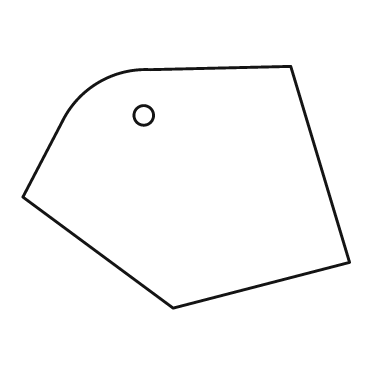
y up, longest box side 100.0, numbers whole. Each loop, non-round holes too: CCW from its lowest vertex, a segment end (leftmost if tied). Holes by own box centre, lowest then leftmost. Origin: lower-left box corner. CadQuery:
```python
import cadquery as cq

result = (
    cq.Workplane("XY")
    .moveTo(46.0, 0.0)
    .lineTo(100.0, 14.0)
    .lineTo(82.0, 74.0)
    .lineTo(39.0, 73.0)
    .threePointArc((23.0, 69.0), (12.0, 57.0))
    .lineTo(0.0, 34.0)
    .close()
    .moveTo(37.0, 59.0)
    .circle(3.0)
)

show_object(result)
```